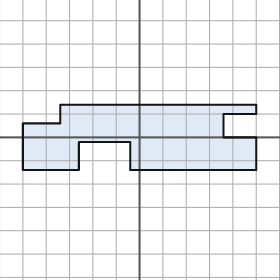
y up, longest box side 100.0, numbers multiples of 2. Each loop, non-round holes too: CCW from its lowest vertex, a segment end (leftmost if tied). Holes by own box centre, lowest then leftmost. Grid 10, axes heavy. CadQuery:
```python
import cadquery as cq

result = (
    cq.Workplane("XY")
    .moveTo(-50.0, -14.0)
    .lineTo(-26.0, -14.0)
    .lineTo(-26.0, -2.0)
    .lineTo(-4.0, -2.0)
    .lineTo(-4.0, -14.0)
    .lineTo(50.0, -14.0)
    .lineTo(50.0, 0.0)
    .lineTo(36.0, 0.0)
    .lineTo(36.0, 10.0)
    .lineTo(50.0, 10.0)
    .lineTo(50.0, 14.0)
    .lineTo(-34.0, 14.0)
    .lineTo(-34.0, 6.0)
    .lineTo(-50.0, 6.0)
    .close()
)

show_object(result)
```